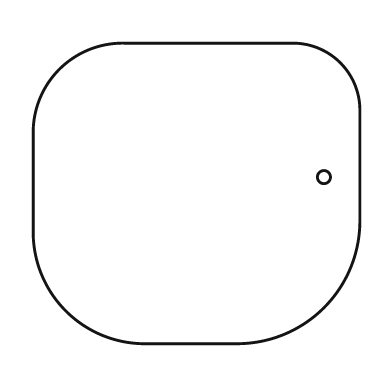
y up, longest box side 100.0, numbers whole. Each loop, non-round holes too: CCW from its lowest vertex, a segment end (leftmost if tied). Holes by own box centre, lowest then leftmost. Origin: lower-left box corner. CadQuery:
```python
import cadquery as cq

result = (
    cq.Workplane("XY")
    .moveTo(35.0, 0.0)
    .lineTo(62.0, 0.0)
    .threePointArc((89.0, 11.0), (100.0, 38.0))
    .lineTo(100.0, 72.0)
    .threePointArc((94.0, 86.0), (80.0, 92.0))
    .lineTo(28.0, 92.0)
    .threePointArc((8.0, 84.0), (0.0, 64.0))
    .lineTo(0.0, 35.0)
    .threePointArc((10.0, 10.0), (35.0, 0.0))
    .close()
    .moveTo(89.0, 51.0)
    .circle(2.0)
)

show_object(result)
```